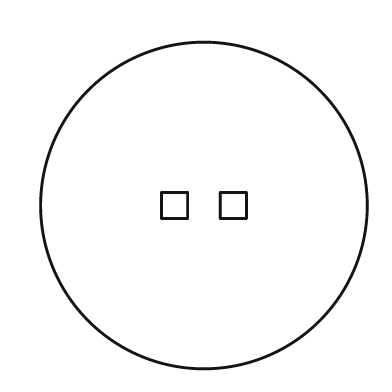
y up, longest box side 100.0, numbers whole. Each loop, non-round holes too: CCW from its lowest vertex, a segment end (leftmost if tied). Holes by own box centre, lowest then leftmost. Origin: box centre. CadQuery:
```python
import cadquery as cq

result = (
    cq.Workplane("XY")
    .moveTo(0.0, 0.0)
    .circle(50.0)
    .moveTo(-13.0, -4.0)
    .lineTo(-5.0, -4.0)
    .lineTo(-5.0, 4.0)
    .lineTo(-13.0, 4.0)
    .close()
    .moveTo(5.0, -4.0)
    .lineTo(13.0, -4.0)
    .lineTo(13.0, 4.0)
    .lineTo(5.0, 4.0)
    .close()
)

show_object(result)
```